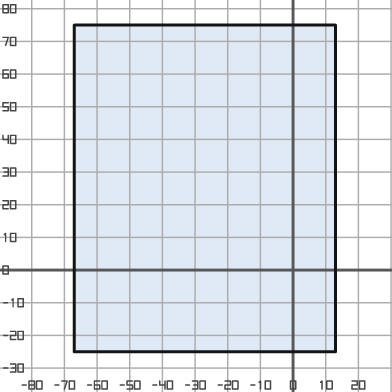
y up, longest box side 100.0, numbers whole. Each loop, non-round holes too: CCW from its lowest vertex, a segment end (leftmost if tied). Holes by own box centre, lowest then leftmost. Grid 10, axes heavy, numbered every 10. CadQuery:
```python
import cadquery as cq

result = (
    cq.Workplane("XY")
    .moveTo(-67.0, -25.0)
    .lineTo(13.0, -25.0)
    .lineTo(13.0, 75.0)
    .lineTo(-67.0, 75.0)
    .close()
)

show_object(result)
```